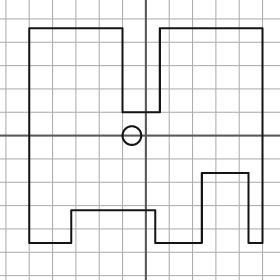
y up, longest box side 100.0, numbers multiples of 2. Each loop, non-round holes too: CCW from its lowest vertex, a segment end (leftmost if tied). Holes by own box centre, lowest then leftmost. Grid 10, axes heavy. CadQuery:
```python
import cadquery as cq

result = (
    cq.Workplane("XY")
    .moveTo(-50.0, -46.0)
    .lineTo(-32.0, -46.0)
    .lineTo(-32.0, -32.0)
    .lineTo(4.0, -32.0)
    .lineTo(4.0, -46.0)
    .lineTo(24.0, -46.0)
    .lineTo(24.0, -16.0)
    .lineTo(44.0, -16.0)
    .lineTo(44.0, -46.0)
    .lineTo(50.0, -46.0)
    .lineTo(50.0, 46.0)
    .lineTo(6.0, 46.0)
    .lineTo(6.0, 10.0)
    .lineTo(-10.0, 10.0)
    .lineTo(-10.0, 46.0)
    .lineTo(-50.0, 46.0)
    .close()
    .moveTo(-6.0, 0.0)
    .circle(4.0)
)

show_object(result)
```